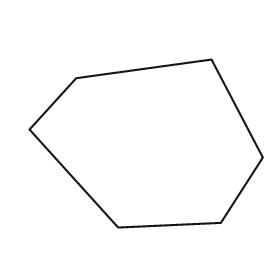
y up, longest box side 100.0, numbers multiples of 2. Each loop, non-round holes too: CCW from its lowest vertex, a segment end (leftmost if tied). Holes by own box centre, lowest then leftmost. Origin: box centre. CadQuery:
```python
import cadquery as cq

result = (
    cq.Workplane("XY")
    .moveTo(-12.0, -36.0)
    .lineTo(32.0, -34.0)
    .lineTo(50.0, -6.0)
    .lineTo(28.0, 36.0)
    .lineTo(-30.0, 28.0)
    .lineTo(-50.0, 6.0)
    .close()
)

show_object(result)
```